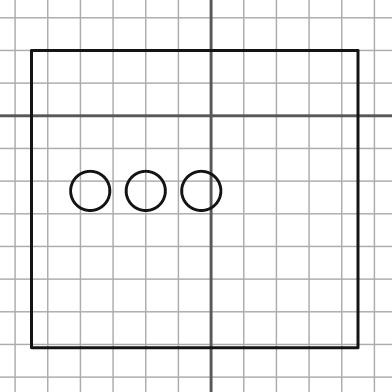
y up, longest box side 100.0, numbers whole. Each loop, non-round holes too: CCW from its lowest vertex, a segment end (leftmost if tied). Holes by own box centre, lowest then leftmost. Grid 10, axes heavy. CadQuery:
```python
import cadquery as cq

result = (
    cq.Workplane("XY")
    .moveTo(-55.0, -71.0)
    .lineTo(45.0, -71.0)
    .lineTo(45.0, 20.0)
    .lineTo(-55.0, 20.0)
    .close()
    .moveTo(-37.0, -23.0)
    .circle(6.0)
    .moveTo(-20.0, -23.0)
    .circle(6.0)
    .moveTo(-3.0, -23.0)
    .circle(6.0)
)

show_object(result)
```